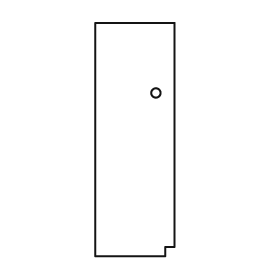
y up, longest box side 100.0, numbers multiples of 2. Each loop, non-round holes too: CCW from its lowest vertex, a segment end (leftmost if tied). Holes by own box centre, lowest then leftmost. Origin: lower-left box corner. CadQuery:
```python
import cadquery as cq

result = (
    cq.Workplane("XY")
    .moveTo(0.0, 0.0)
    .lineTo(30.0, 0.0)
    .lineTo(30.0, 4.0)
    .lineTo(34.0, 4.0)
    .lineTo(34.0, 100.0)
    .lineTo(0.0, 100.0)
    .close()
    .moveTo(26.0, 70.0)
    .circle(2.0)
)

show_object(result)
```